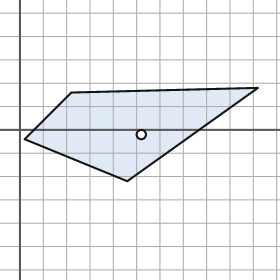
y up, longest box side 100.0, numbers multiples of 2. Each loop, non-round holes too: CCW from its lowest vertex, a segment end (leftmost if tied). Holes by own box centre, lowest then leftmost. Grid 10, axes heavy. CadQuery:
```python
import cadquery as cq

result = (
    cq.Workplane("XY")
    .moveTo(46.0, -22.0)
    .lineTo(102.0, 18.0)
    .lineTo(22.0, 16.0)
    .lineTo(2.0, -4.0)
    .close()
    .moveTo(52.0, -2.0)
    .circle(2.0)
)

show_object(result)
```